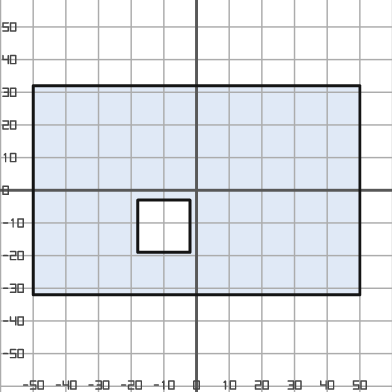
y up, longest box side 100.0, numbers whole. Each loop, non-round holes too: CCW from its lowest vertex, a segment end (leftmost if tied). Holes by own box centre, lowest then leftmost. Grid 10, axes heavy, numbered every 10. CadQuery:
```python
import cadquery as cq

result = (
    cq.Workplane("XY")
    .moveTo(-50.0, -32.0)
    .lineTo(50.0, -32.0)
    .lineTo(50.0, 32.0)
    .lineTo(-50.0, 32.0)
    .close()
    .moveTo(-18.0, -19.0)
    .lineTo(-2.0, -19.0)
    .lineTo(-2.0, -3.0)
    .lineTo(-18.0, -3.0)
    .close()
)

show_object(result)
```